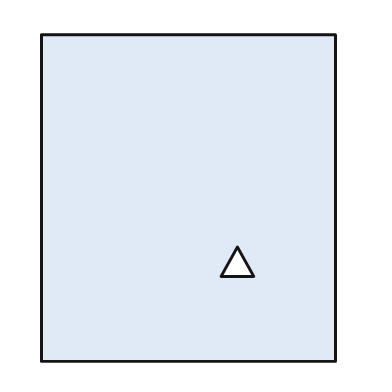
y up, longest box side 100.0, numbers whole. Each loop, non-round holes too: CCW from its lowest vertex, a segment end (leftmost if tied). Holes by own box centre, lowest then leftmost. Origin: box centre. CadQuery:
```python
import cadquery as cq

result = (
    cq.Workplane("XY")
    .moveTo(-45.0, -50.0)
    .lineTo(45.0, -50.0)
    .lineTo(45.0, 50.0)
    .lineTo(-45.0, 50.0)
    .close()
    .moveTo(10.0, -24.0)
    .lineTo(20.0, -24.0)
    .lineTo(15.0, -15.0)
    .close()
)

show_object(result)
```